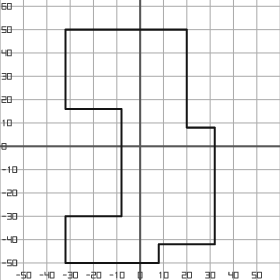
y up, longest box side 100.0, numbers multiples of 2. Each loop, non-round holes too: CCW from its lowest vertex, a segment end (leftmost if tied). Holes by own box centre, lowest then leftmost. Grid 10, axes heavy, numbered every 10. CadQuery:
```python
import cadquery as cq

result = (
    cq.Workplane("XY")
    .moveTo(-32.0, -50.0)
    .lineTo(8.0, -50.0)
    .lineTo(8.0, -42.0)
    .lineTo(32.0, -42.0)
    .lineTo(32.0, 8.0)
    .lineTo(20.0, 8.0)
    .lineTo(20.0, 50.0)
    .lineTo(-32.0, 50.0)
    .lineTo(-32.0, 16.0)
    .lineTo(-8.0, 16.0)
    .lineTo(-8.0, -30.0)
    .lineTo(-32.0, -30.0)
    .close()
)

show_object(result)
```